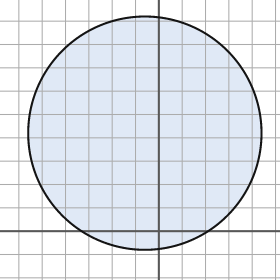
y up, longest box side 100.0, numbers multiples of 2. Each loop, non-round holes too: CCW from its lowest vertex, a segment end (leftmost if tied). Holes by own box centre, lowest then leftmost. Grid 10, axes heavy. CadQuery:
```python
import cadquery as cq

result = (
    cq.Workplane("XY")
    .moveTo(-6.0, 42.0)
    .circle(50.0)
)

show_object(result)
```